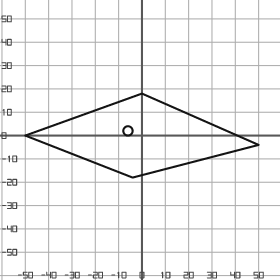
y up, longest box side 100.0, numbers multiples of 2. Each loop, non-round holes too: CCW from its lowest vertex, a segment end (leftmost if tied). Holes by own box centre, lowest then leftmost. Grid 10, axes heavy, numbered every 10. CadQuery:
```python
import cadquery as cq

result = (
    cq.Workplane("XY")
    .moveTo(-4.0, -18.0)
    .lineTo(50.0, -4.0)
    .lineTo(0.0, 18.0)
    .lineTo(-50.0, 0.0)
    .close()
    .moveTo(-6.0, 2.0)
    .circle(2.0)
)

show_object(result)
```